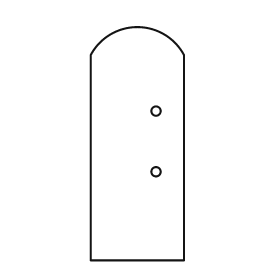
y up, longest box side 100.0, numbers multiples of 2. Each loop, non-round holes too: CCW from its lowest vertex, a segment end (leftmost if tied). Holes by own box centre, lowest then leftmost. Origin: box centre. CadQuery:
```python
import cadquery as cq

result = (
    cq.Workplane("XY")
    .moveTo(-20.0, -50.0)
    .lineTo(20.0, -50.0)
    .lineTo(20.0, 38.0)
    .threePointArc((0.0, 50.0), (-20.0, 38.0))
    .close()
    .moveTo(8.0, -12.0)
    .circle(2.0)
    .moveTo(8.0, 14.0)
    .circle(2.0)
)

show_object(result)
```